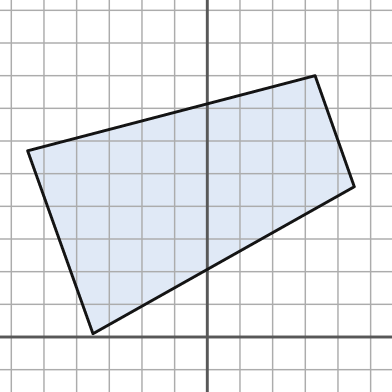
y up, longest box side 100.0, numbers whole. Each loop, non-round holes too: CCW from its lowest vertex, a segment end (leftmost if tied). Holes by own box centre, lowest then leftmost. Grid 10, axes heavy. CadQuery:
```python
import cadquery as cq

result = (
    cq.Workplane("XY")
    .moveTo(-35.0, 1.0)
    .lineTo(45.0, 46.0)
    .lineTo(33.0, 80.0)
    .lineTo(-55.0, 57.0)
    .close()
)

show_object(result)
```